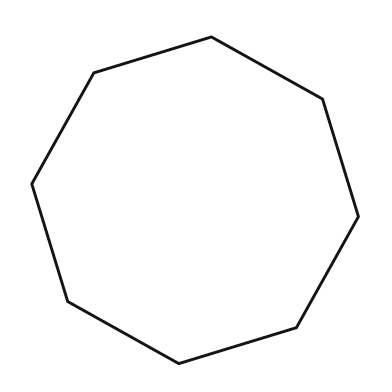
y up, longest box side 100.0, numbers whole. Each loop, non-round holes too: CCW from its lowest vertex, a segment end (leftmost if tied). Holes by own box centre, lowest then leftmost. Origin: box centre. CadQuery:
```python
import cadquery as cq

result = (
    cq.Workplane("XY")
    .moveTo(-5.0, -50.0)
    .lineTo(31.0, -39.0)
    .lineTo(50.0, -5.0)
    .lineTo(39.0, 31.0)
    .lineTo(5.0, 50.0)
    .lineTo(-31.0, 39.0)
    .lineTo(-50.0, 5.0)
    .lineTo(-39.0, -31.0)
    .close()
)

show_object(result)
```